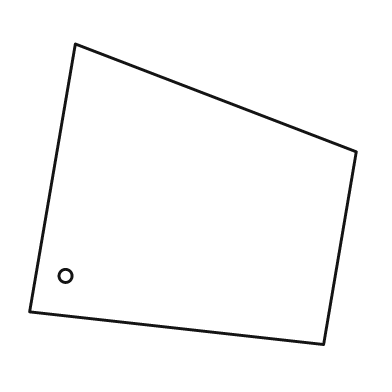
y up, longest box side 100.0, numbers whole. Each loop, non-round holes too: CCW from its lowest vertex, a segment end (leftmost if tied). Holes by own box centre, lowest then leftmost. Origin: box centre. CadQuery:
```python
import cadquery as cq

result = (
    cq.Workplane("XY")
    .moveTo(40.0, -46.0)
    .lineTo(50.0, 13.0)
    .lineTo(-36.0, 46.0)
    .lineTo(-50.0, -36.0)
    .close()
    .moveTo(-39.0, -25.0)
    .circle(2.0)
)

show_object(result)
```